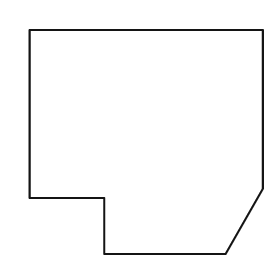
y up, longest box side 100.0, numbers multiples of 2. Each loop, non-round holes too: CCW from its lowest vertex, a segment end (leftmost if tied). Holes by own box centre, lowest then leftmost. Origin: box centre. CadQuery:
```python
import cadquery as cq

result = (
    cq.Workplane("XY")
    .moveTo(-18.0, -48.0)
    .lineTo(34.0, -48.0)
    .lineTo(50.0, -20.0)
    .lineTo(50.0, 48.0)
    .lineTo(-50.0, 48.0)
    .lineTo(-50.0, -24.0)
    .lineTo(-18.0, -24.0)
    .close()
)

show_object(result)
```